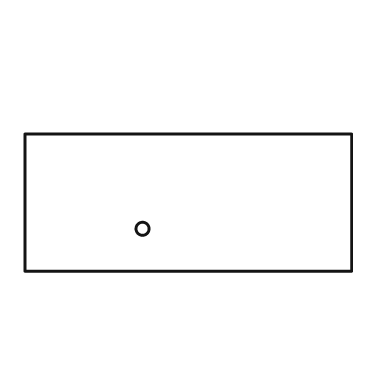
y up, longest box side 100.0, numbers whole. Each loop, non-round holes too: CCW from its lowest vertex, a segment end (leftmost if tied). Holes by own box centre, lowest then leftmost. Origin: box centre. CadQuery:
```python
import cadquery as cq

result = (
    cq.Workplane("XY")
    .moveTo(-50.0, -21.0)
    .lineTo(50.0, -21.0)
    .lineTo(50.0, 21.0)
    .lineTo(-50.0, 21.0)
    .close()
    .moveTo(-14.0, -8.0)
    .circle(2.0)
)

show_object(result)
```